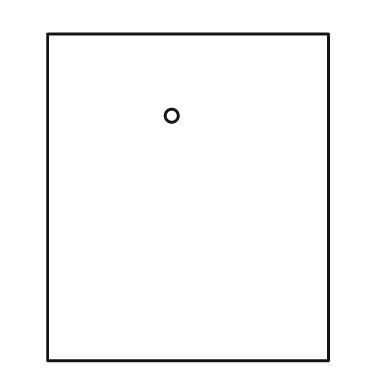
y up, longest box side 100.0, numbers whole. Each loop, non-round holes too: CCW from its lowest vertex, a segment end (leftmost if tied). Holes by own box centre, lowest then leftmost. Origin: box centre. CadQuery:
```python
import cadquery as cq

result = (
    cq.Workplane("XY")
    .moveTo(-43.0, -50.0)
    .lineTo(43.0, -50.0)
    .lineTo(43.0, 50.0)
    .lineTo(-43.0, 50.0)
    .close()
    .moveTo(-5.0, 25.0)
    .circle(2.0)
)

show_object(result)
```